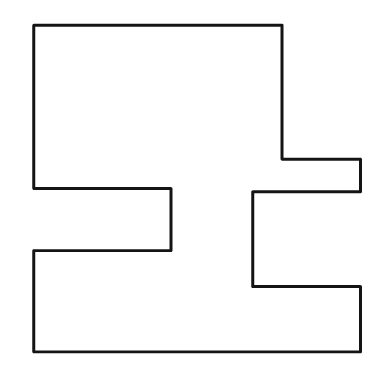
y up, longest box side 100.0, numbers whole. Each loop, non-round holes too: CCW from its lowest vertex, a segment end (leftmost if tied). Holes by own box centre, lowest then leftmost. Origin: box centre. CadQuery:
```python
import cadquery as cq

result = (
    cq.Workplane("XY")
    .moveTo(-50.0, -50.0)
    .lineTo(50.0, -50.0)
    .lineTo(50.0, -30.0)
    .lineTo(17.0, -30.0)
    .lineTo(17.0, -1.0)
    .lineTo(50.0, -1.0)
    .lineTo(50.0, 9.0)
    .lineTo(26.0, 9.0)
    .lineTo(26.0, 50.0)
    .lineTo(-50.0, 50.0)
    .lineTo(-50.0, 0.0)
    .lineTo(-8.0, 0.0)
    .lineTo(-8.0, -19.0)
    .lineTo(-50.0, -19.0)
    .close()
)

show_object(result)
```